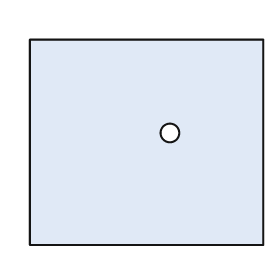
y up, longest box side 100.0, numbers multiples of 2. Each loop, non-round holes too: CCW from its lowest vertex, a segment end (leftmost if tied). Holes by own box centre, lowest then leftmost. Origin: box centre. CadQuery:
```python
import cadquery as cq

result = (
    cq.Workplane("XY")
    .moveTo(-50.0, -44.0)
    .lineTo(50.0, -44.0)
    .lineTo(50.0, 44.0)
    .lineTo(-50.0, 44.0)
    .close()
    .moveTo(10.0, 4.0)
    .circle(4.0)
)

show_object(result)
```